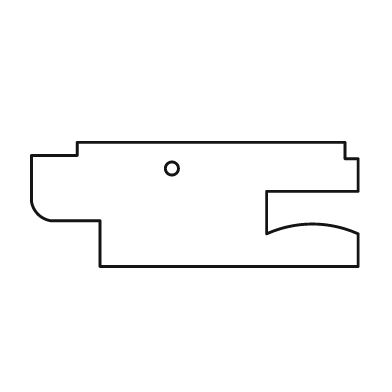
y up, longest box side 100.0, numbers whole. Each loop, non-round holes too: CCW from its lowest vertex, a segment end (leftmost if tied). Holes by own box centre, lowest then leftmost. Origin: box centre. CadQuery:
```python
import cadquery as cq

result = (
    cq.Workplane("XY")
    .moveTo(-29.0, -19.0)
    .lineTo(50.0, -19.0)
    .lineTo(50.0, -9.0)
    .threePointArc((36.0, -6.0), (22.0, -9.0))
    .lineTo(22.0, 4.0)
    .lineTo(50.0, 4.0)
    .lineTo(50.0, 14.0)
    .lineTo(46.0, 14.0)
    .lineTo(46.0, 19.0)
    .lineTo(-36.0, 19.0)
    .lineTo(-36.0, 15.0)
    .lineTo(-50.0, 15.0)
    .lineTo(-50.0, 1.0)
    .threePointArc((-48.0, -3.0), (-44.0, -5.0))
    .lineTo(-29.0, -5.0)
    .close()
    .moveTo(-7.0, 11.0)
    .circle(2.0)
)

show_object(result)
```